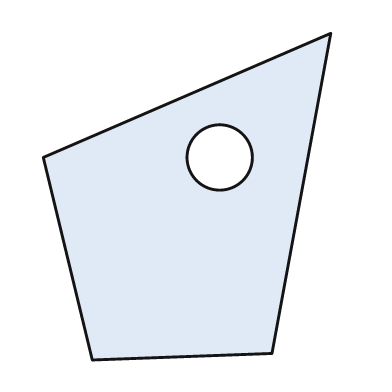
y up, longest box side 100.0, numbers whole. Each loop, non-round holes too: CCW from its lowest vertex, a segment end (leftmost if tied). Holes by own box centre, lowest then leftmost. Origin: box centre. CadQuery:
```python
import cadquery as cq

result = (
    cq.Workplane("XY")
    .moveTo(-29.0, -50.0)
    .lineTo(26.0, -48.0)
    .lineTo(44.0, 50.0)
    .lineTo(-44.0, 12.0)
    .close()
    .moveTo(10.0, 12.0)
    .circle(10.0)
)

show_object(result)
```